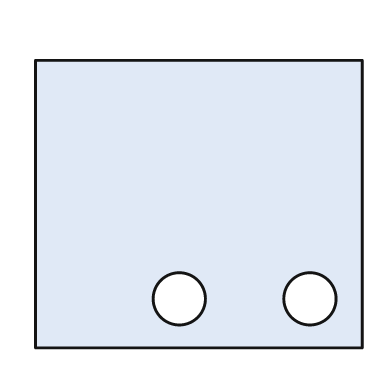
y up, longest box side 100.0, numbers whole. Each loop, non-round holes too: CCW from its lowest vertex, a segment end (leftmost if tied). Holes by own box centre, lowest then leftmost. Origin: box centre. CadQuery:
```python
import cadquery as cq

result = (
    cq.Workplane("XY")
    .moveTo(-50.0, -44.0)
    .lineTo(50.0, -44.0)
    .lineTo(50.0, 44.0)
    .lineTo(-50.0, 44.0)
    .close()
    .moveTo(-6.0, -29.0)
    .circle(8.0)
    .moveTo(34.0, -29.0)
    .circle(8.0)
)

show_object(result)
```